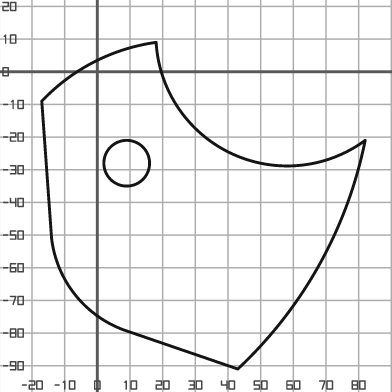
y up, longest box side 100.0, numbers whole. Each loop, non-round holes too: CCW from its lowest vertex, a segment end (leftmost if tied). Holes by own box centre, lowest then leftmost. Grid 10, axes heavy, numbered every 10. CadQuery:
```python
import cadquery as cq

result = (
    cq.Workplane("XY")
    .moveTo(43.0, -91.0)
    .threePointArc((68.0, -59.0), (82.0, -21.0))
    .threePointArc((41.0, -25.0), (18.0, 9.0))
    .threePointArc((-1.0, 3.0), (-17.0, -9.0))
    .lineTo(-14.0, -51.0)
    .threePointArc((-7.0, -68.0), (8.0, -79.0))
    .close()
    .moveTo(9.0, -28.0)
    .circle(7.0)
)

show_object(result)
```